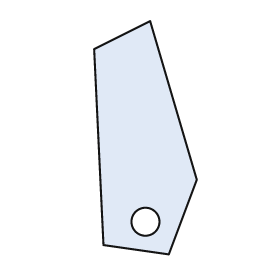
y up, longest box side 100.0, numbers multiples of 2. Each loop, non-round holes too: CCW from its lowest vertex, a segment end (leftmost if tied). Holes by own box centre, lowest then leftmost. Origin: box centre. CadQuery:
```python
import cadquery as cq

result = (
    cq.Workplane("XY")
    .moveTo(10.0, -50.0)
    .lineTo(22.0, -18.0)
    .lineTo(2.0, 50.0)
    .lineTo(-22.0, 38.0)
    .lineTo(-18.0, -46.0)
    .close()
    .moveTo(0.0, -36.0)
    .circle(6.0)
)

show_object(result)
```